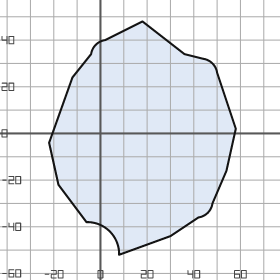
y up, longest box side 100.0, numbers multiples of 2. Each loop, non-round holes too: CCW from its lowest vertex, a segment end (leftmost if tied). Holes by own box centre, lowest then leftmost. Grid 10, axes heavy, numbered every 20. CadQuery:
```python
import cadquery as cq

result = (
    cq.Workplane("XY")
    .moveTo(8.0, -52.0)
    .lineTo(30.0, -44.0)
    .lineTo(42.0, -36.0)
    .threePointArc((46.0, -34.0), (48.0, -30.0))
    .lineTo(54.0, -16.0)
    .lineTo(58.0, 2.0)
    .lineTo(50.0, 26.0)
    .threePointArc((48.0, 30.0), (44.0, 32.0))
    .lineTo(36.0, 34.0)
    .lineTo(18.0, 48.0)
    .lineTo(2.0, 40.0)
    .threePointArc((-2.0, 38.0), (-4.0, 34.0))
    .lineTo(-12.0, 24.0)
    .lineTo(-22.0, -4.0)
    .lineTo(-18.0, -22.0)
    .lineTo(-6.0, -38.0)
    .threePointArc((4.0, -42.0), (8.0, -52.0))
    .close()
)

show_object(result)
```